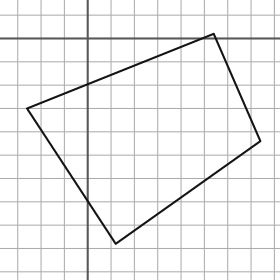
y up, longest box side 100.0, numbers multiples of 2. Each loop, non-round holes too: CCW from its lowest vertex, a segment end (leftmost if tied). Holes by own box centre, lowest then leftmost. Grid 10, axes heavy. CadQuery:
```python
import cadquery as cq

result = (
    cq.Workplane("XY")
    .moveTo(12.0, -88.0)
    .lineTo(74.0, -44.0)
    .lineTo(54.0, 2.0)
    .lineTo(-26.0, -30.0)
    .close()
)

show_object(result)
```